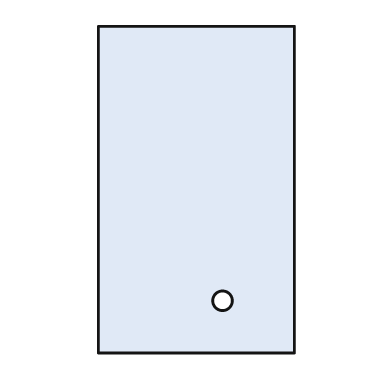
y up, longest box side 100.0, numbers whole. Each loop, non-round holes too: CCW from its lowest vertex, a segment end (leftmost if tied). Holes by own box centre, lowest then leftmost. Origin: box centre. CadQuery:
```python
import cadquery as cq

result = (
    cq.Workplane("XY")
    .moveTo(-30.0, -50.0)
    .lineTo(30.0, -50.0)
    .lineTo(30.0, 50.0)
    .lineTo(-30.0, 50.0)
    .close()
    .moveTo(8.0, -34.0)
    .circle(3.0)
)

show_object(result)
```